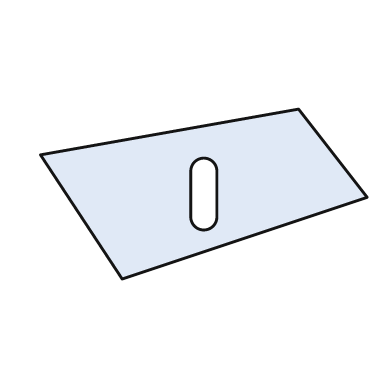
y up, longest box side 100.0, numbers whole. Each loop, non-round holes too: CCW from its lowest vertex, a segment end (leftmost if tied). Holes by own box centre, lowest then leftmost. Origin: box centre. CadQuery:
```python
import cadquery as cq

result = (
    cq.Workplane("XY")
    .moveTo(-25.0, -26.0)
    .lineTo(50.0, -1.0)
    .lineTo(29.0, 26.0)
    .lineTo(-50.0, 12.0)
    .close()
    .moveTo(-4.0, -7.0)
    .threePointArc((0.0, -11.0), (4.0, -7.0))
    .lineTo(4.0, 7.0)
    .threePointArc((0.0, 11.0), (-4.0, 7.0))
    .close()
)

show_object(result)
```